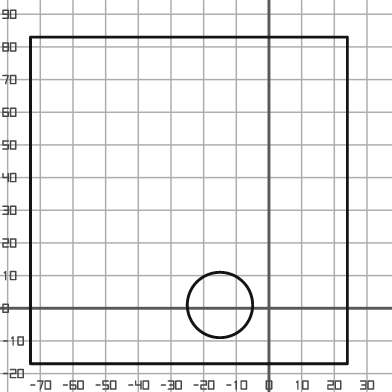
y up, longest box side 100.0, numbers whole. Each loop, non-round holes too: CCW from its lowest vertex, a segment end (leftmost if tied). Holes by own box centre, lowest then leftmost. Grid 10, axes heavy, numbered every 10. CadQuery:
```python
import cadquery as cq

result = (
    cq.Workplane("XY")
    .moveTo(-73.0, -17.0)
    .lineTo(24.0, -17.0)
    .lineTo(24.0, 83.0)
    .lineTo(-73.0, 83.0)
    .close()
    .moveTo(-15.0, 1.0)
    .circle(10.0)
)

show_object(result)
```